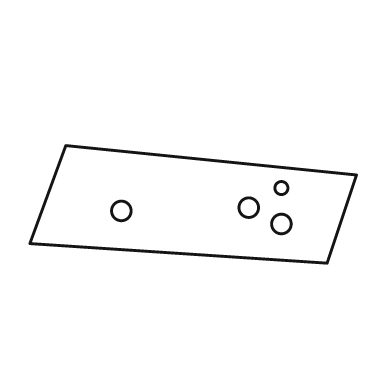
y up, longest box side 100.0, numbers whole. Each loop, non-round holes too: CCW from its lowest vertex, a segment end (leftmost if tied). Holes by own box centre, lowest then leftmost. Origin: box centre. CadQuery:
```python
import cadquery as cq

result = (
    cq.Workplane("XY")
    .moveTo(41.0, -18.0)
    .lineTo(50.0, 9.0)
    .lineTo(-39.0, 18.0)
    .lineTo(-50.0, -12.0)
    .close()
    .moveTo(27.0, -6.0)
    .circle(3.0)
    .moveTo(-22.0, -2.0)
    .circle(3.0)
    .moveTo(17.0, -1.0)
    .circle(3.0)
    .moveTo(27.0, 5.0)
    .circle(2.0)
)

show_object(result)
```